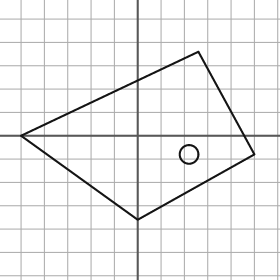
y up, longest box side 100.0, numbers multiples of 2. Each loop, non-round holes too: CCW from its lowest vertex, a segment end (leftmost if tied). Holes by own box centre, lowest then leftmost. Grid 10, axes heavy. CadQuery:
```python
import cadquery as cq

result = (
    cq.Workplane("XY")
    .moveTo(0.0, -36.0)
    .lineTo(50.0, -8.0)
    .lineTo(26.0, 36.0)
    .lineTo(-50.0, 0.0)
    .close()
    .moveTo(22.0, -8.0)
    .circle(4.0)
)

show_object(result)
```